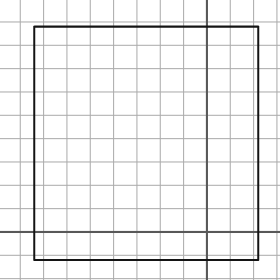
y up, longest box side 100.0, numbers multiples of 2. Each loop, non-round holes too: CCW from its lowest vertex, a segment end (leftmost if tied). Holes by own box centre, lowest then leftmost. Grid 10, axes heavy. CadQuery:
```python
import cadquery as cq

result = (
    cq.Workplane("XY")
    .moveTo(-74.0, -12.0)
    .lineTo(22.0, -12.0)
    .lineTo(22.0, 88.0)
    .lineTo(-74.0, 88.0)
    .close()
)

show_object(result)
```